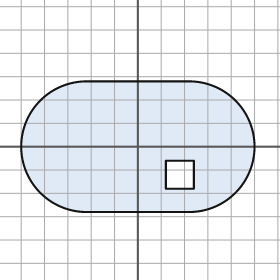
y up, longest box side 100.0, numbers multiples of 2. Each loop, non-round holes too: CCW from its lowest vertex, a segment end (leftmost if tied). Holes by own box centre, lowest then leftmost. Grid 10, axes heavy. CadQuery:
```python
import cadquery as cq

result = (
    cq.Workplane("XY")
    .moveTo(-22.0, -28.0)
    .lineTo(22.0, -28.0)
    .threePointArc((50.0, 0.0), (22.0, 28.0))
    .lineTo(-22.0, 28.0)
    .threePointArc((-50.0, 0.0), (-22.0, -28.0))
    .close()
    .moveTo(12.0, -18.0)
    .lineTo(24.0, -18.0)
    .lineTo(24.0, -6.0)
    .lineTo(12.0, -6.0)
    .close()
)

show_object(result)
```